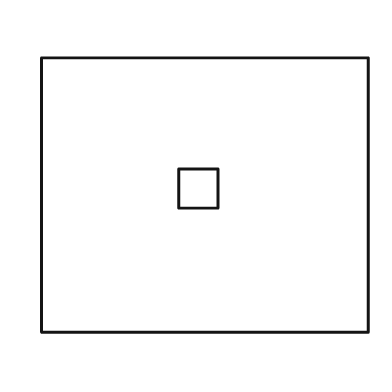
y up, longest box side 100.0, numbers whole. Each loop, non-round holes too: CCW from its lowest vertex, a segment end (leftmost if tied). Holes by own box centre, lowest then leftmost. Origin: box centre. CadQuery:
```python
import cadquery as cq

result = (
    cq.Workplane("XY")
    .moveTo(-50.0, -42.0)
    .lineTo(50.0, -42.0)
    .lineTo(50.0, 42.0)
    .lineTo(-50.0, 42.0)
    .close()
    .moveTo(-8.0, -4.0)
    .lineTo(4.0, -4.0)
    .lineTo(4.0, 8.0)
    .lineTo(-8.0, 8.0)
    .close()
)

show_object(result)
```